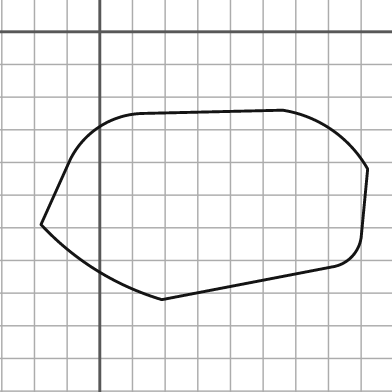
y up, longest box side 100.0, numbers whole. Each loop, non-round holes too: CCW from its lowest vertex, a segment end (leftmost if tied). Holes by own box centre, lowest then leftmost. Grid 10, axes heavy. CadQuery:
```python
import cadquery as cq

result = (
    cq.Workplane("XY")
    .moveTo(19.0, -82.0)
    .lineTo(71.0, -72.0)
    .threePointArc((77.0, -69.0), (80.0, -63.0))
    .lineTo(82.0, -42.0)
    .threePointArc((71.0, -30.0), (56.0, -24.0))
    .lineTo(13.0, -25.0)
    .threePointArc((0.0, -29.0), (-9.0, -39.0))
    .lineTo(-18.0, -59.0)
    .threePointArc((-1.0, -73.0), (19.0, -82.0))
    .close()
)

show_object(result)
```